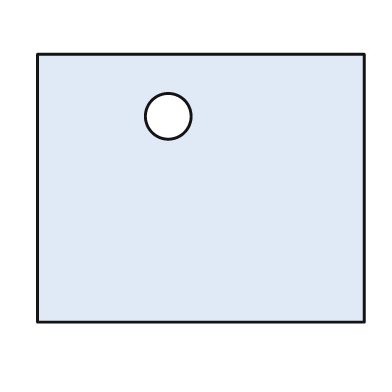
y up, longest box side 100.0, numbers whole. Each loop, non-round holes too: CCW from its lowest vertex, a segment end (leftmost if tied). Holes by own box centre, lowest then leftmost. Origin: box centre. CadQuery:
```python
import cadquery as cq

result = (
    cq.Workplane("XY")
    .moveTo(-50.0, -41.0)
    .lineTo(50.0, -41.0)
    .lineTo(50.0, 41.0)
    .lineTo(-50.0, 41.0)
    .close()
    .moveTo(-10.0, 22.0)
    .circle(7.0)
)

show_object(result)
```